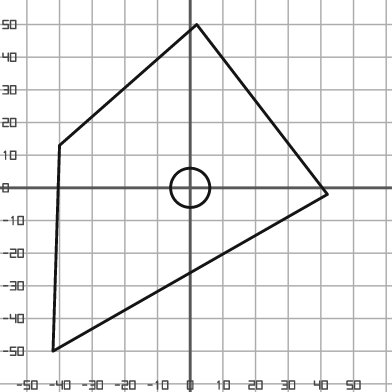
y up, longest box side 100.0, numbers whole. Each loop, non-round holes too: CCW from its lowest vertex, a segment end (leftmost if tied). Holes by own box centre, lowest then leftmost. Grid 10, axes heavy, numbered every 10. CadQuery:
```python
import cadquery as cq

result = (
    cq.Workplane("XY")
    .moveTo(-42.0, -50.0)
    .lineTo(42.0, -2.0)
    .lineTo(2.0, 50.0)
    .lineTo(-40.0, 13.0)
    .close()
    .moveTo(0.0, 0.0)
    .circle(6.0)
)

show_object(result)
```